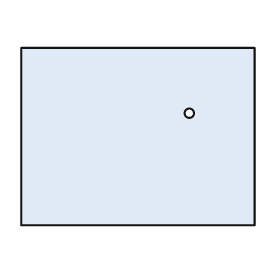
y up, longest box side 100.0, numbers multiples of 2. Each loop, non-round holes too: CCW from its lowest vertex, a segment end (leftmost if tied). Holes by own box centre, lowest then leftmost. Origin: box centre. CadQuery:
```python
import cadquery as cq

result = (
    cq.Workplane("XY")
    .moveTo(-50.0, -38.0)
    .lineTo(50.0, -38.0)
    .lineTo(50.0, 38.0)
    .lineTo(-50.0, 38.0)
    .close()
    .moveTo(22.0, 10.0)
    .circle(2.0)
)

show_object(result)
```